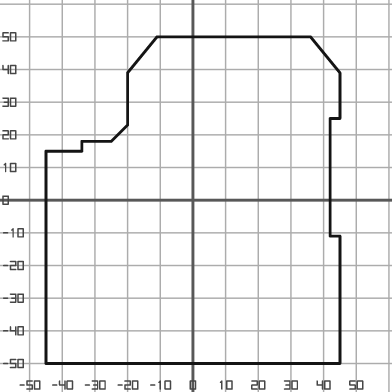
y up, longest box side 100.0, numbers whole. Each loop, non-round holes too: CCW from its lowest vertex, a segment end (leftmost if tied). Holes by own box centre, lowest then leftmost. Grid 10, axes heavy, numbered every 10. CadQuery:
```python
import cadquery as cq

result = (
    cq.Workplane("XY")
    .moveTo(-45.0, -50.0)
    .lineTo(45.0, -50.0)
    .lineTo(45.0, -11.0)
    .lineTo(42.0, -11.0)
    .lineTo(42.0, 25.0)
    .lineTo(45.0, 25.0)
    .lineTo(45.0, 39.0)
    .lineTo(36.0, 50.0)
    .lineTo(-11.0, 50.0)
    .lineTo(-20.0, 39.0)
    .lineTo(-20.0, 23.0)
    .lineTo(-25.0, 18.0)
    .lineTo(-34.0, 18.0)
    .lineTo(-34.0, 15.0)
    .lineTo(-45.0, 15.0)
    .close()
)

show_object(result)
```